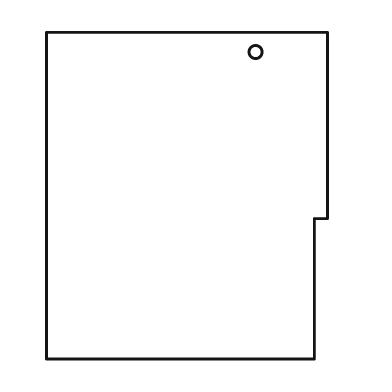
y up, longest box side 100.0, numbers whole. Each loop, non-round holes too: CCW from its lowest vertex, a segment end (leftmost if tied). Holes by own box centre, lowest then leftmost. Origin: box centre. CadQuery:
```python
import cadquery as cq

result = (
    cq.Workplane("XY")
    .moveTo(-43.0, -50.0)
    .lineTo(39.0, -50.0)
    .lineTo(39.0, -7.0)
    .lineTo(43.0, -7.0)
    .lineTo(43.0, 50.0)
    .lineTo(-43.0, 50.0)
    .close()
    .moveTo(21.0, 44.0)
    .circle(2.0)
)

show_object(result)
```